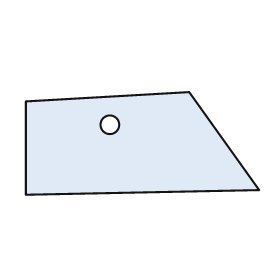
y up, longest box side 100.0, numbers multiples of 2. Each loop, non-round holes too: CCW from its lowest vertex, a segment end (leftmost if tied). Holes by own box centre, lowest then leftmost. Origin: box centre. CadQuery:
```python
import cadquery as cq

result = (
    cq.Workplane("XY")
    .moveTo(-50.0, -22.0)
    .lineTo(50.0, -20.0)
    .lineTo(20.0, 22.0)
    .lineTo(-50.0, 18.0)
    .close()
    .moveTo(-14.0, 8.0)
    .circle(4.0)
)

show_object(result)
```